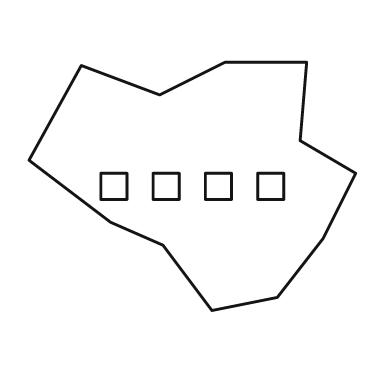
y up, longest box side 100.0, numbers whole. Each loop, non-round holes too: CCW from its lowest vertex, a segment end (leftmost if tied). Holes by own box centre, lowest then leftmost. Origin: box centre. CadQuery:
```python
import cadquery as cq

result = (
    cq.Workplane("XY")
    .moveTo(6.0, -38.0)
    .lineTo(26.0, -34.0)
    .lineTo(40.0, -16.0)
    .lineTo(50.0, 4.0)
    .lineTo(33.0, 14.0)
    .lineTo(35.0, 38.0)
    .lineTo(10.0, 38.0)
    .lineTo(-10.0, 28.0)
    .lineTo(-34.0, 37.0)
    .lineTo(-50.0, 8.0)
    .lineTo(-25.0, -11.0)
    .lineTo(-9.0, -18.0)
    .close()
    .moveTo(-28.0, -4.0)
    .lineTo(-20.0, -4.0)
    .lineTo(-20.0, 4.0)
    .lineTo(-28.0, 4.0)
    .close()
    .moveTo(-12.0, -4.0)
    .lineTo(-4.0, -4.0)
    .lineTo(-4.0, 4.0)
    .lineTo(-12.0, 4.0)
    .close()
    .moveTo(4.0, -4.0)
    .lineTo(12.0, -4.0)
    .lineTo(12.0, 4.0)
    .lineTo(4.0, 4.0)
    .close()
    .moveTo(20.0, -4.0)
    .lineTo(28.0, -4.0)
    .lineTo(28.0, 4.0)
    .lineTo(20.0, 4.0)
    .close()
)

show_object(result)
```